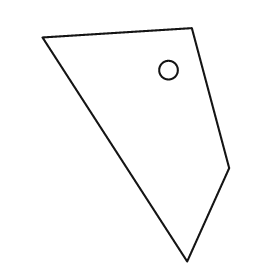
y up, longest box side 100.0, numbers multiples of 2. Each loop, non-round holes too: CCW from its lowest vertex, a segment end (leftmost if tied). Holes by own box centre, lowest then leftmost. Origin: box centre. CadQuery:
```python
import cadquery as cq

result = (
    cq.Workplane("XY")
    .moveTo(22.0, -50.0)
    .lineTo(40.0, -10.0)
    .lineTo(24.0, 50.0)
    .lineTo(-40.0, 46.0)
    .close()
    .moveTo(14.0, 32.0)
    .circle(4.0)
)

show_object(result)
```